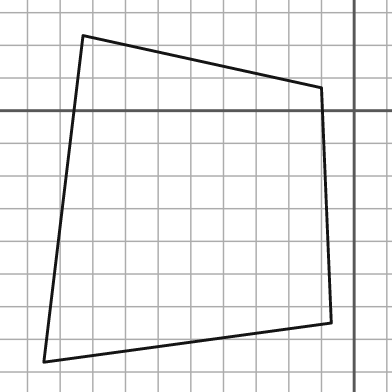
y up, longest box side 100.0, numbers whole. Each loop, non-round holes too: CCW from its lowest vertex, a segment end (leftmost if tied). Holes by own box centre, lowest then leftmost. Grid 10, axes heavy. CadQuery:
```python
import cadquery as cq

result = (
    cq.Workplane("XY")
    .moveTo(-95.0, -77.0)
    .lineTo(-7.0, -65.0)
    .lineTo(-10.0, 7.0)
    .lineTo(-83.0, 23.0)
    .close()
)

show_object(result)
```